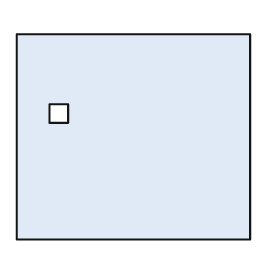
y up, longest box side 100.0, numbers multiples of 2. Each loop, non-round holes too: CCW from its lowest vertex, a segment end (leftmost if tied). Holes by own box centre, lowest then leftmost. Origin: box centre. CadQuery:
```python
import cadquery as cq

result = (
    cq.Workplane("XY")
    .moveTo(-50.0, -44.0)
    .lineTo(50.0, -44.0)
    .lineTo(50.0, 44.0)
    .lineTo(-50.0, 44.0)
    .close()
    .moveTo(-36.0, 6.0)
    .lineTo(-28.0, 6.0)
    .lineTo(-28.0, 14.0)
    .lineTo(-36.0, 14.0)
    .close()
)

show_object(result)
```